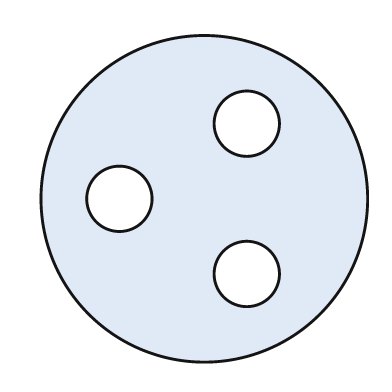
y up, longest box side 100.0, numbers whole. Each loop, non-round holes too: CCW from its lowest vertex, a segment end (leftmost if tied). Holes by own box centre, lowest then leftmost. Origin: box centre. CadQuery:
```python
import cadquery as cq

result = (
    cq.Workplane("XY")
    .moveTo(0.0, 0.0)
    .circle(50.0)
    .moveTo(13.0, -23.0)
    .circle(10.0)
    .moveTo(-26.0, 0.0)
    .circle(10.0)
    .moveTo(13.0, 23.0)
    .circle(10.0)
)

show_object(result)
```